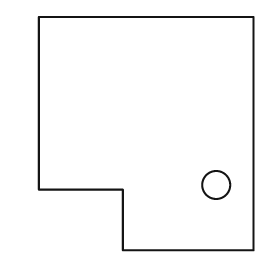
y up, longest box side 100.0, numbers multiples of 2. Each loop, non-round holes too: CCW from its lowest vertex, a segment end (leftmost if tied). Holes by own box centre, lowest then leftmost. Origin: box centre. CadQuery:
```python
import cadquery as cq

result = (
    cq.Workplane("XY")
    .moveTo(-10.0, -50.0)
    .lineTo(46.0, -50.0)
    .lineTo(46.0, 50.0)
    .lineTo(-46.0, 50.0)
    .lineTo(-46.0, -24.0)
    .lineTo(-10.0, -24.0)
    .close()
    .moveTo(30.0, -22.0)
    .circle(6.0)
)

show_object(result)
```